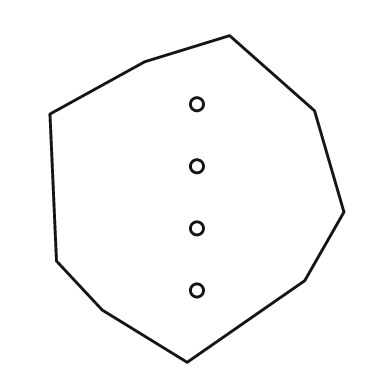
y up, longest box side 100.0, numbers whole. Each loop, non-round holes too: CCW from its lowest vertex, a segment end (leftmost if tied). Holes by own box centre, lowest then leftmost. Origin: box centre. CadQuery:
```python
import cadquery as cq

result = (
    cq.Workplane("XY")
    .moveTo(-3.0, -50.0)
    .lineTo(33.0, -25.0)
    .lineTo(45.0, -4.0)
    .lineTo(36.0, 27.0)
    .lineTo(10.0, 50.0)
    .lineTo(-16.0, 42.0)
    .lineTo(-45.0, 26.0)
    .lineTo(-43.0, -19.0)
    .lineTo(-29.0, -34.0)
    .close()
    .moveTo(0.0, -28.0)
    .circle(2.0)
    .moveTo(0.0, -9.0)
    .circle(2.0)
    .moveTo(0.0, 10.0)
    .circle(2.0)
    .moveTo(0.0, 29.0)
    .circle(2.0)
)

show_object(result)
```